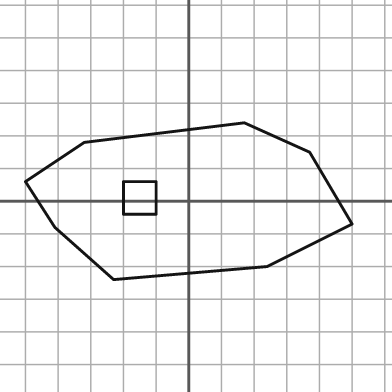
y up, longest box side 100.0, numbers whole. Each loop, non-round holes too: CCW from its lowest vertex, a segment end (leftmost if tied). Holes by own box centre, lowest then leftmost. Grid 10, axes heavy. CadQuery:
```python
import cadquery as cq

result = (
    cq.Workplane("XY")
    .moveTo(-23.0, -24.0)
    .lineTo(24.0, -20.0)
    .lineTo(50.0, -7.0)
    .lineTo(37.0, 15.0)
    .lineTo(17.0, 24.0)
    .lineTo(-32.0, 18.0)
    .lineTo(-50.0, 6.0)
    .lineTo(-41.0, -8.0)
    .close()
    .moveTo(-20.0, -4.0)
    .lineTo(-10.0, -4.0)
    .lineTo(-10.0, 6.0)
    .lineTo(-20.0, 6.0)
    .close()
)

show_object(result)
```